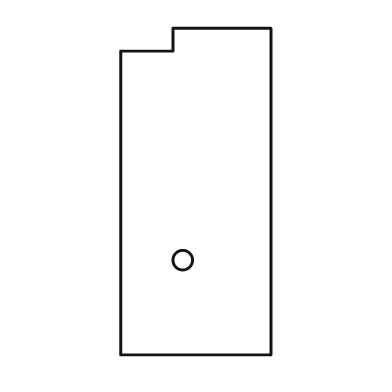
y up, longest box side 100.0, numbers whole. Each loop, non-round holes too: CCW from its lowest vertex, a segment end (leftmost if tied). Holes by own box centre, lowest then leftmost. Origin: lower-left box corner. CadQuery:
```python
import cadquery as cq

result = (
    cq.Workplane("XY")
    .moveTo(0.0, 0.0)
    .lineTo(46.0, 0.0)
    .lineTo(46.0, 100.0)
    .lineTo(16.0, 100.0)
    .lineTo(16.0, 93.0)
    .lineTo(0.0, 93.0)
    .close()
    .moveTo(19.0, 29.0)
    .circle(3.0)
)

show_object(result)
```